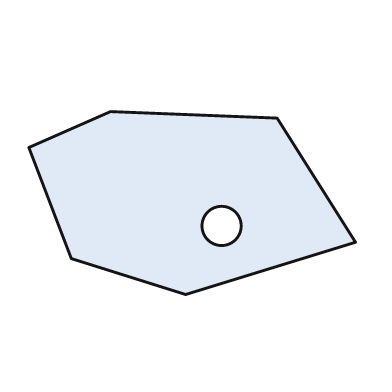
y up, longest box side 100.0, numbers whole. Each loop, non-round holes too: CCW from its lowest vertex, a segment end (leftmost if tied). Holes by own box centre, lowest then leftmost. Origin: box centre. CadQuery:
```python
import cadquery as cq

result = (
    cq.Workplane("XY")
    .moveTo(-2.0, -28.0)
    .lineTo(50.0, -12.0)
    .lineTo(26.0, 26.0)
    .lineTo(-25.0, 28.0)
    .lineTo(-50.0, 17.0)
    .lineTo(-37.0, -17.0)
    .close()
    .moveTo(9.0, -7.0)
    .circle(6.0)
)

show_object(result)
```